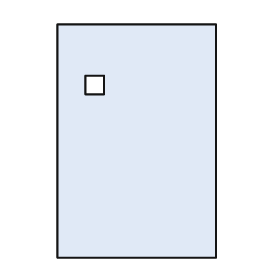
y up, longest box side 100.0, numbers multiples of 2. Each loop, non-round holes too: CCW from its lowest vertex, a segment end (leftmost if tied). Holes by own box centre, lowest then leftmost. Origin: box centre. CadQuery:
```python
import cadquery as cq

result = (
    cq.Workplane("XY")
    .moveTo(-34.0, -50.0)
    .lineTo(34.0, -50.0)
    .lineTo(34.0, 50.0)
    .lineTo(-34.0, 50.0)
    .close()
    .moveTo(-22.0, 20.0)
    .lineTo(-14.0, 20.0)
    .lineTo(-14.0, 28.0)
    .lineTo(-22.0, 28.0)
    .close()
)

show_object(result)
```